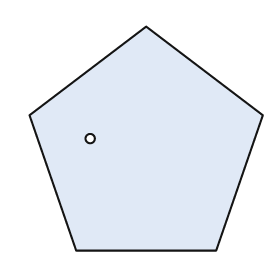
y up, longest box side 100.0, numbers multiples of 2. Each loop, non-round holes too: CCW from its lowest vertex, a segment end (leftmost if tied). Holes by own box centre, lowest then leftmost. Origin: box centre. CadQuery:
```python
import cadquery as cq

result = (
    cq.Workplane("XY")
    .moveTo(-30.0, -48.0)
    .lineTo(30.0, -48.0)
    .lineTo(50.0, 10.0)
    .lineTo(0.0, 48.0)
    .lineTo(-50.0, 10.0)
    .close()
    .moveTo(-24.0, 0.0)
    .circle(2.0)
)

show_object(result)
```